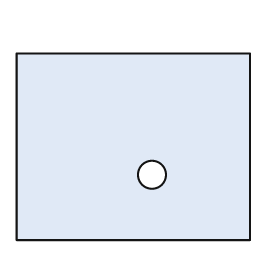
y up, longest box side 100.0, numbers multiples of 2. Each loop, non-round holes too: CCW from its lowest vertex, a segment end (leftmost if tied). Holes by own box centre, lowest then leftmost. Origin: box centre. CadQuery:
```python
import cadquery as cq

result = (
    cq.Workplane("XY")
    .moveTo(-50.0, -40.0)
    .lineTo(50.0, -40.0)
    .lineTo(50.0, 40.0)
    .lineTo(-50.0, 40.0)
    .close()
    .moveTo(8.0, -12.0)
    .circle(6.0)
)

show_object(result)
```